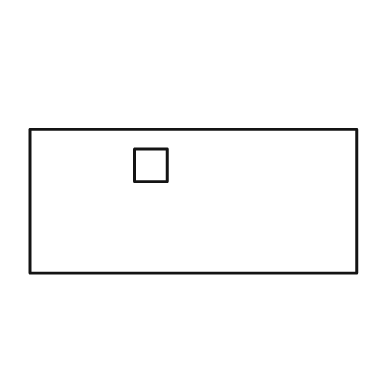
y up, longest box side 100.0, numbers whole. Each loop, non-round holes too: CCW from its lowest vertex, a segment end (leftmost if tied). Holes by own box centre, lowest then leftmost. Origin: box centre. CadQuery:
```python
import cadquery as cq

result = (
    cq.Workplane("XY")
    .moveTo(-50.0, -22.0)
    .lineTo(50.0, -22.0)
    .lineTo(50.0, 22.0)
    .lineTo(-50.0, 22.0)
    .close()
    .moveTo(-18.0, 6.0)
    .lineTo(-8.0, 6.0)
    .lineTo(-8.0, 16.0)
    .lineTo(-18.0, 16.0)
    .close()
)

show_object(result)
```